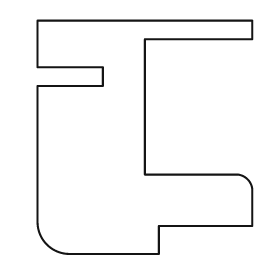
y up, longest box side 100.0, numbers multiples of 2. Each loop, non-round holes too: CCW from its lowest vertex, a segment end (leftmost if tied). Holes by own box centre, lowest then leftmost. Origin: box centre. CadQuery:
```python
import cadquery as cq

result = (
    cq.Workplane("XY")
    .moveTo(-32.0, -50.0)
    .lineTo(6.0, -50.0)
    .lineTo(6.0, -38.0)
    .lineTo(46.0, -38.0)
    .lineTo(46.0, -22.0)
    .threePointArc((44.0, -18.0), (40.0, -16.0))
    .lineTo(0.0, -16.0)
    .lineTo(0.0, 42.0)
    .lineTo(46.0, 42.0)
    .lineTo(46.0, 50.0)
    .lineTo(-46.0, 50.0)
    .lineTo(-46.0, 30.0)
    .lineTo(-18.0, 30.0)
    .lineTo(-18.0, 22.0)
    .lineTo(-46.0, 22.0)
    .lineTo(-46.0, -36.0)
    .threePointArc((-42.0, -46.0), (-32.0, -50.0))
    .close()
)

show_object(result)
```